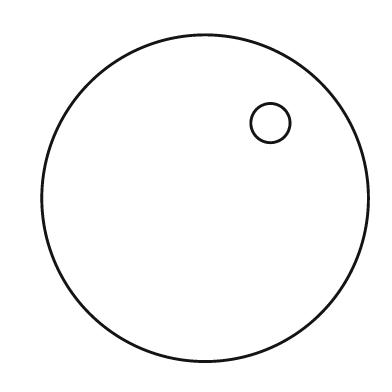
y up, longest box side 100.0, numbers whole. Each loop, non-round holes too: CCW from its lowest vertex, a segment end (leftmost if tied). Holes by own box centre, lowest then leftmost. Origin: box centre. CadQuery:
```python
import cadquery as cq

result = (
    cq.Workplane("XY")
    .moveTo(0.0, 0.0)
    .circle(50.0)
    .moveTo(20.0, 23.0)
    .circle(6.0)
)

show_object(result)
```